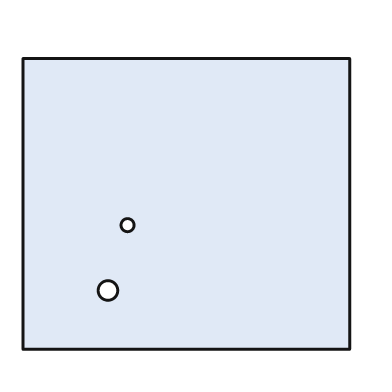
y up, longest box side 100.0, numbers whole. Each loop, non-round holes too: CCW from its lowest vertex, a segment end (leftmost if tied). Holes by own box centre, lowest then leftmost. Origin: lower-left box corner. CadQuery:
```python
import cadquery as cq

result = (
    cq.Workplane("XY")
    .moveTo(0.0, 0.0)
    .lineTo(100.0, 0.0)
    .lineTo(100.0, 89.0)
    .lineTo(0.0, 89.0)
    .close()
    .moveTo(26.0, 18.0)
    .circle(3.0)
    .moveTo(32.0, 38.0)
    .circle(2.0)
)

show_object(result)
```